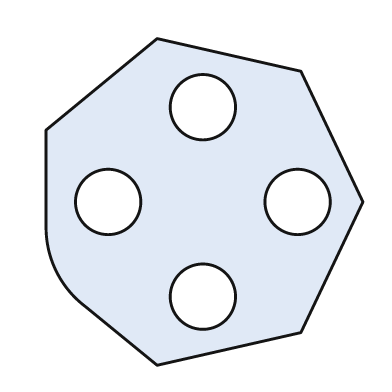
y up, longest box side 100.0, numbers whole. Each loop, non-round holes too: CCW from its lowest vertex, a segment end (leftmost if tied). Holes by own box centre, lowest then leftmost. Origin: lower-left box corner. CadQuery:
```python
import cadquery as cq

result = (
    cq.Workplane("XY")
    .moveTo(34.0, 0.0)
    .lineTo(78.0, 10.0)
    .lineTo(97.0, 50.0)
    .lineTo(78.0, 90.0)
    .lineTo(34.0, 100.0)
    .lineTo(0.0, 72.0)
    .lineTo(0.0, 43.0)
    .threePointArc((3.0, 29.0), (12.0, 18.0))
    .close()
    .moveTo(48.0, 21.0)
    .circle(10.0)
    .moveTo(19.0, 50.0)
    .circle(10.0)
    .moveTo(77.0, 50.0)
    .circle(10.0)
    .moveTo(48.0, 79.0)
    .circle(10.0)
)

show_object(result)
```